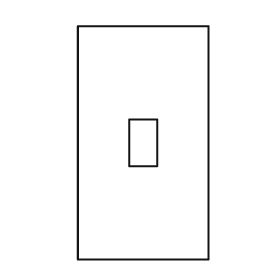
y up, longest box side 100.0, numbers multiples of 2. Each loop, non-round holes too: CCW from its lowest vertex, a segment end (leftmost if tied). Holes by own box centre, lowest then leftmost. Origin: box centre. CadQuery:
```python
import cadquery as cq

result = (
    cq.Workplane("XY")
    .moveTo(-28.0, -50.0)
    .lineTo(28.0, -50.0)
    .lineTo(28.0, 50.0)
    .lineTo(-28.0, 50.0)
    .close()
    .moveTo(-6.0, -10.0)
    .lineTo(6.0, -10.0)
    .lineTo(6.0, 10.0)
    .lineTo(-6.0, 10.0)
    .close()
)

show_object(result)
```